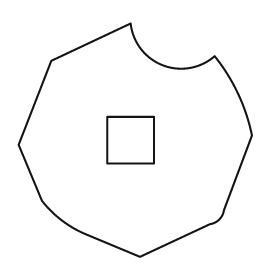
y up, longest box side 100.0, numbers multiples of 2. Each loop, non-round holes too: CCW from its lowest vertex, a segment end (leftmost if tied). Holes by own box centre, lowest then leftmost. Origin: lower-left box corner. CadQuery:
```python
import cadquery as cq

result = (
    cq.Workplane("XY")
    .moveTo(52.0, 0.0)
    .lineTo(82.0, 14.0)
    .threePointArc((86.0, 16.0), (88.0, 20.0))
    .lineTo(100.0, 52.0)
    .threePointArc((94.0, 70.0), (84.0, 86.0))
    .threePointArc((62.0, 82.0), (48.0, 100.0))
    .lineTo(14.0, 84.0)
    .lineTo(0.0, 48.0)
    .lineTo(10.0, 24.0)
    .threePointArc((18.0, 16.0), (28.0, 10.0))
    .close()
    .moveTo(38.0, 40.0)
    .lineTo(58.0, 40.0)
    .lineTo(58.0, 60.0)
    .lineTo(38.0, 60.0)
    .close()
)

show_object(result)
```